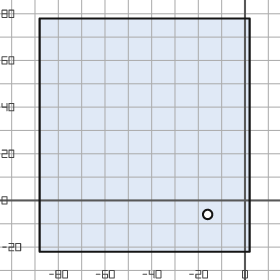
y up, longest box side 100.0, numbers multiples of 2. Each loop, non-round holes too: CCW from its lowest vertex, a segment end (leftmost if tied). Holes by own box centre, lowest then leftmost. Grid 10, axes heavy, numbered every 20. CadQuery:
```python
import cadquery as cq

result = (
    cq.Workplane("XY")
    .moveTo(-88.0, -22.0)
    .lineTo(2.0, -22.0)
    .lineTo(2.0, 78.0)
    .lineTo(-88.0, 78.0)
    .close()
    .moveTo(-16.0, -6.0)
    .circle(2.0)
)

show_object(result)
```